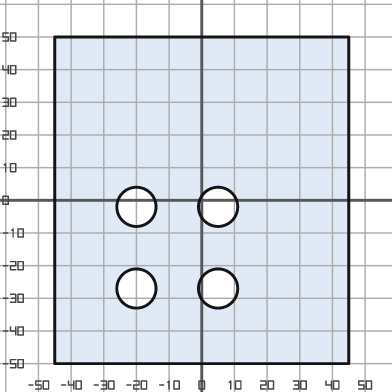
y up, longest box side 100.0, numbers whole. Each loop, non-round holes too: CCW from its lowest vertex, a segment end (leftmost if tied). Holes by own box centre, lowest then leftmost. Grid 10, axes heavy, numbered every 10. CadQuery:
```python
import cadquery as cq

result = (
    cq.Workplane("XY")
    .moveTo(-45.0, -50.0)
    .lineTo(45.0, -50.0)
    .lineTo(45.0, 50.0)
    .lineTo(-45.0, 50.0)
    .close()
    .moveTo(-20.0, -27.0)
    .circle(6.0)
    .moveTo(5.0, -27.0)
    .circle(6.0)
    .moveTo(-20.0, -2.0)
    .circle(6.0)
    .moveTo(5.0, -2.0)
    .circle(6.0)
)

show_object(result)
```